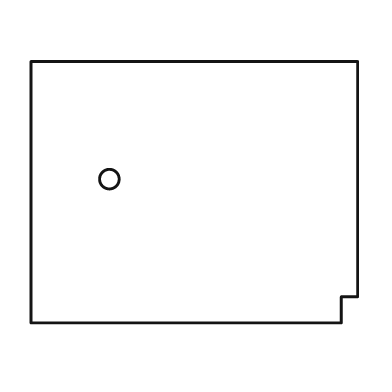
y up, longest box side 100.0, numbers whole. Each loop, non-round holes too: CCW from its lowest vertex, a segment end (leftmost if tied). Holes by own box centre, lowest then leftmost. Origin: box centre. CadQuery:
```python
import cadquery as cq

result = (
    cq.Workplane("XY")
    .moveTo(-50.0, -40.0)
    .lineTo(45.0, -40.0)
    .lineTo(45.0, -32.0)
    .lineTo(50.0, -32.0)
    .lineTo(50.0, 40.0)
    .lineTo(-50.0, 40.0)
    .close()
    .moveTo(-26.0, 4.0)
    .circle(3.0)
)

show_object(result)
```